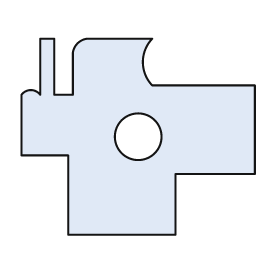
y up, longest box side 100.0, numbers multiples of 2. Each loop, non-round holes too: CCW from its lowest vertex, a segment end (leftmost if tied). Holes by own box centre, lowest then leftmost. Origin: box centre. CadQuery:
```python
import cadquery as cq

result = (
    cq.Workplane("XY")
    .moveTo(-30.0, -42.0)
    .lineTo(16.0, -42.0)
    .lineTo(16.0, -16.0)
    .lineTo(50.0, -16.0)
    .lineTo(50.0, 22.0)
    .lineTo(6.0, 22.0)
    .threePointArc((2.0, 32.0), (6.0, 42.0))
    .lineTo(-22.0, 42.0)
    .threePointArc((-26.0, 40.0), (-28.0, 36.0))
    .lineTo(-28.0, 18.0)
    .lineTo(-36.0, 18.0)
    .lineTo(-36.0, 42.0)
    .lineTo(-42.0, 42.0)
    .lineTo(-42.0, 18.0)
    .threePointArc((-46.0, 20.0), (-50.0, 18.0))
    .lineTo(-50.0, -8.0)
    .lineTo(-30.0, -8.0)
    .close()
    .moveTo(0.0, 0.0)
    .circle(10.0)
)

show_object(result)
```